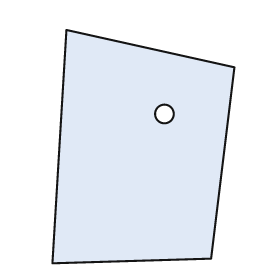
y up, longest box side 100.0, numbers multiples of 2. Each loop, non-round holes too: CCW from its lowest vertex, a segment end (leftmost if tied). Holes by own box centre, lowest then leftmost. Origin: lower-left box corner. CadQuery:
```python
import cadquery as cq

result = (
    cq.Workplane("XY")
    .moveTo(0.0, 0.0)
    .lineTo(68.0, 2.0)
    .lineTo(78.0, 84.0)
    .lineTo(6.0, 100.0)
    .close()
    .moveTo(48.0, 64.0)
    .circle(4.0)
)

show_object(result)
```